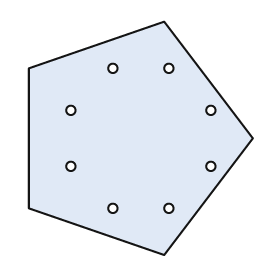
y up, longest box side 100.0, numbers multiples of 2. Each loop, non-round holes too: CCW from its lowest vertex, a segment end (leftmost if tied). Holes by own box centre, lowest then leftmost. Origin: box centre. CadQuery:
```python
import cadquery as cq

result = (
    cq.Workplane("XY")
    .moveTo(10.0, -50.0)
    .lineTo(48.0, 0.0)
    .lineTo(10.0, 50.0)
    .lineTo(-48.0, 30.0)
    .lineTo(-48.0, -30.0)
    .close()
    .moveTo(-12.0, -30.0)
    .circle(2.0)
    .moveTo(12.0, -30.0)
    .circle(2.0)
    .moveTo(-30.0, -12.0)
    .circle(2.0)
    .moveTo(30.0, -12.0)
    .circle(2.0)
    .moveTo(-30.0, 12.0)
    .circle(2.0)
    .moveTo(30.0, 12.0)
    .circle(2.0)
    .moveTo(-12.0, 30.0)
    .circle(2.0)
    .moveTo(12.0, 30.0)
    .circle(2.0)
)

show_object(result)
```